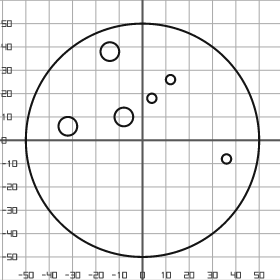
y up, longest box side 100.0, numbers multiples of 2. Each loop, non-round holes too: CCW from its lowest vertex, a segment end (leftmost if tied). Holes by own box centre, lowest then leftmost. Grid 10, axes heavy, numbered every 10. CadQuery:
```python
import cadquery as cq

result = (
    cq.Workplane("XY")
    .moveTo(0.0, 0.0)
    .circle(50.0)
    .moveTo(36.0, -8.0)
    .circle(2.0)
    .moveTo(-32.0, 6.0)
    .circle(4.0)
    .moveTo(-8.0, 10.0)
    .circle(4.0)
    .moveTo(4.0, 18.0)
    .circle(2.0)
    .moveTo(12.0, 26.0)
    .circle(2.0)
    .moveTo(-14.0, 38.0)
    .circle(4.0)
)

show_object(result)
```